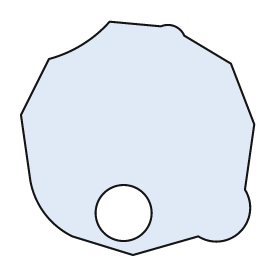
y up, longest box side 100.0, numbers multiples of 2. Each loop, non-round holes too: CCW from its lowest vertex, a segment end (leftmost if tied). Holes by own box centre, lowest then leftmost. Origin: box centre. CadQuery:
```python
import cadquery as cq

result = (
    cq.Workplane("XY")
    .moveTo(-2.0, -50.0)
    .lineTo(26.0, -42.0)
    .threePointArc((44.0, -40.0), (46.0, -22.0))
    .lineTo(50.0, 6.0)
    .lineTo(40.0, 32.0)
    .lineTo(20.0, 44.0)
    .threePointArc((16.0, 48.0), (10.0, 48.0))
    .lineTo(-12.0, 50.0)
    .threePointArc((-24.0, 40.0), (-38.0, 34.0))
    .lineTo(-50.0, 10.0)
    .lineTo(-46.0, -18.0)
    .threePointArc((-40.0, -32.0), (-28.0, -42.0))
    .close()
    .moveTo(-6.0, -32.0)
    .circle(12.0)
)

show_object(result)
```